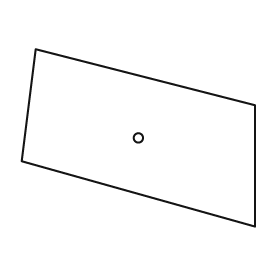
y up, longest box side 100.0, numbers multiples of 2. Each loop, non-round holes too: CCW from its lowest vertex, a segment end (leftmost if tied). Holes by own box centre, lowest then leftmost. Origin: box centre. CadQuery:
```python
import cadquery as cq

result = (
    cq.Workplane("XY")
    .moveTo(50.0, -38.0)
    .lineTo(50.0, 14.0)
    .lineTo(-44.0, 38.0)
    .lineTo(-50.0, -10.0)
    .close()
    .moveTo(0.0, 0.0)
    .circle(2.0)
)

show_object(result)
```